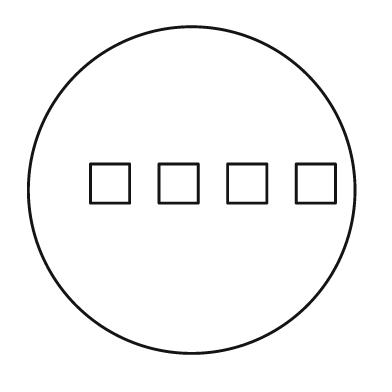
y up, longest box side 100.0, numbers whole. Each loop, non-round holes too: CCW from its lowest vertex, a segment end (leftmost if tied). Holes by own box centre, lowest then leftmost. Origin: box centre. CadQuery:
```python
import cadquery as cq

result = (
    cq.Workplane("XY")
    .moveTo(0.0, 0.0)
    .circle(50.0)
    .moveTo(-31.0, -4.0)
    .lineTo(-19.0, -4.0)
    .lineTo(-19.0, 8.0)
    .lineTo(-31.0, 8.0)
    .close()
    .moveTo(-10.0, -4.0)
    .lineTo(2.0, -4.0)
    .lineTo(2.0, 8.0)
    .lineTo(-10.0, 8.0)
    .close()
    .moveTo(11.0, -4.0)
    .lineTo(23.0, -4.0)
    .lineTo(23.0, 8.0)
    .lineTo(11.0, 8.0)
    .close()
    .moveTo(32.0, -4.0)
    .lineTo(44.0, -4.0)
    .lineTo(44.0, 8.0)
    .lineTo(32.0, 8.0)
    .close()
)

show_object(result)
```